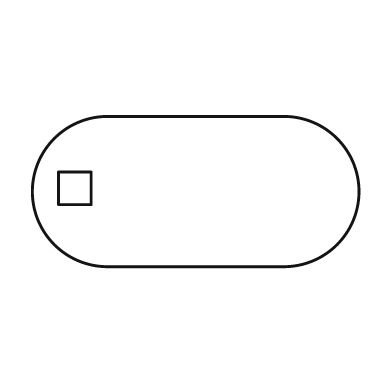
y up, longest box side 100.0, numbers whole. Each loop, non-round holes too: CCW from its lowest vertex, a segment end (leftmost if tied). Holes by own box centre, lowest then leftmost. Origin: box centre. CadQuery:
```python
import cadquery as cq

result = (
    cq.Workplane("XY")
    .moveTo(-27.0, -23.0)
    .lineTo(27.0, -23.0)
    .threePointArc((50.0, 0.0), (27.0, 23.0))
    .lineTo(-27.0, 23.0)
    .threePointArc((-50.0, 0.0), (-27.0, -23.0))
    .close()
    .moveTo(-42.0, -4.0)
    .lineTo(-32.0, -4.0)
    .lineTo(-32.0, 6.0)
    .lineTo(-42.0, 6.0)
    .close()
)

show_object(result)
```